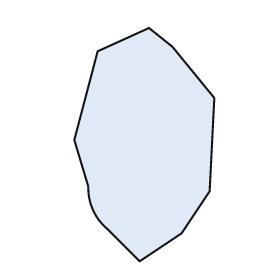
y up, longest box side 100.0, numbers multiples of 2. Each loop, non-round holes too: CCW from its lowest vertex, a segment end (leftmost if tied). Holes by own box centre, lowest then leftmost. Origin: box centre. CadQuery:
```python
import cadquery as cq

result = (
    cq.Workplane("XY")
    .moveTo(-2.0, -50.0)
    .lineTo(16.0, -38.0)
    .lineTo(28.0, -20.0)
    .lineTo(30.0, 20.0)
    .lineTo(12.0, 42.0)
    .lineTo(2.0, 50.0)
    .lineTo(-20.0, 40.0)
    .lineTo(-30.0, 2.0)
    .lineTo(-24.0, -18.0)
    .threePointArc((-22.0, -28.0), (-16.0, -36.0))
    .close()
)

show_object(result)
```